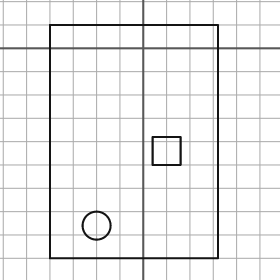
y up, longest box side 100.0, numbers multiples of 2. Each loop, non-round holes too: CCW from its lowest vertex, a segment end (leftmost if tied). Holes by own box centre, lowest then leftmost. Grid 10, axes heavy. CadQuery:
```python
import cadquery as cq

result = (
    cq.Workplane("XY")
    .moveTo(-40.0, -90.0)
    .lineTo(32.0, -90.0)
    .lineTo(32.0, 10.0)
    .lineTo(-40.0, 10.0)
    .close()
    .moveTo(-20.0, -76.0)
    .circle(6.0)
    .moveTo(4.0, -50.0)
    .lineTo(16.0, -50.0)
    .lineTo(16.0, -38.0)
    .lineTo(4.0, -38.0)
    .close()
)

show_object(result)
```